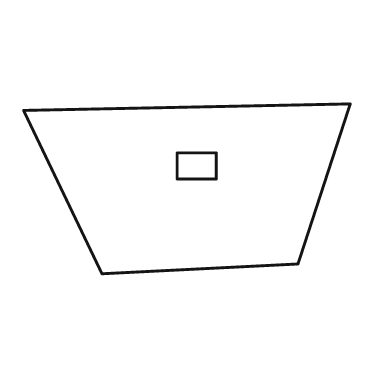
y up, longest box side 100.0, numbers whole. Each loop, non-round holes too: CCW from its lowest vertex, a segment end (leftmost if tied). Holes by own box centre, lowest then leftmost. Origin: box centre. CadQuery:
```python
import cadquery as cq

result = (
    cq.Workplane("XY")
    .moveTo(-26.0, -26.0)
    .lineTo(34.0, -23.0)
    .lineTo(50.0, 26.0)
    .lineTo(-50.0, 24.0)
    .close()
    .moveTo(-3.0, 3.0)
    .lineTo(9.0, 3.0)
    .lineTo(9.0, 11.0)
    .lineTo(-3.0, 11.0)
    .close()
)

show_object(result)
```